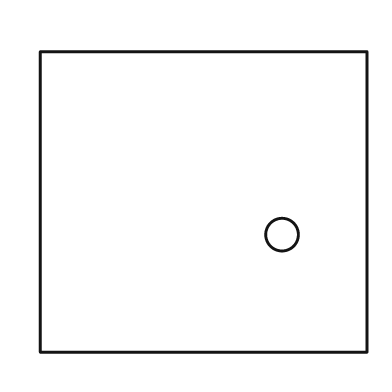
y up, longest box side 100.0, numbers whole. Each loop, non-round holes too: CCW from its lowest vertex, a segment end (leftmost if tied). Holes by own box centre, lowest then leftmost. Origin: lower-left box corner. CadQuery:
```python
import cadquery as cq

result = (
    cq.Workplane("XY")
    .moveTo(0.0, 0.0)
    .lineTo(100.0, 0.0)
    .lineTo(100.0, 92.0)
    .lineTo(0.0, 92.0)
    .close()
    .moveTo(74.0, 36.0)
    .circle(5.0)
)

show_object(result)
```